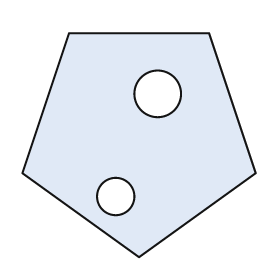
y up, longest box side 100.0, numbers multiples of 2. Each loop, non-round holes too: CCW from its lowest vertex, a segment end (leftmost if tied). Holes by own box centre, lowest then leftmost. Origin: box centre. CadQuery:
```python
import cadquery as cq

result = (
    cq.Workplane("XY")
    .moveTo(0.0, -48.0)
    .lineTo(50.0, -12.0)
    .lineTo(30.0, 48.0)
    .lineTo(-30.0, 48.0)
    .lineTo(-50.0, -12.0)
    .close()
    .moveTo(-10.0, -22.0)
    .circle(8.0)
    .moveTo(8.0, 22.0)
    .circle(10.0)
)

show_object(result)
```